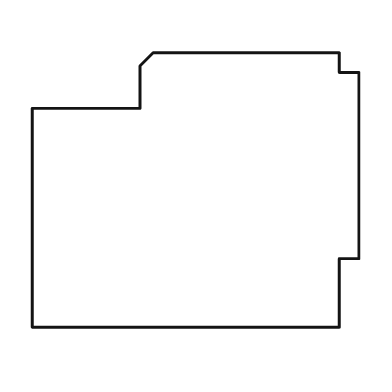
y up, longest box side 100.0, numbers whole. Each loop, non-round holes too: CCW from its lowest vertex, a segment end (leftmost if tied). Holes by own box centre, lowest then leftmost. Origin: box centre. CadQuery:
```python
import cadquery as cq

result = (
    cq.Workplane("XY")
    .moveTo(-50.0, -42.0)
    .lineTo(44.0, -42.0)
    .lineTo(44.0, -21.0)
    .lineTo(50.0, -21.0)
    .lineTo(50.0, 36.0)
    .lineTo(44.0, 36.0)
    .lineTo(44.0, 42.0)
    .lineTo(-13.0, 42.0)
    .lineTo(-17.0, 38.0)
    .lineTo(-17.0, 25.0)
    .lineTo(-50.0, 25.0)
    .close()
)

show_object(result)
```